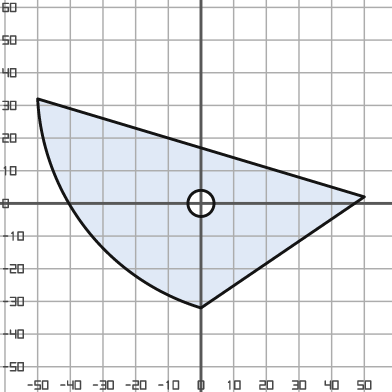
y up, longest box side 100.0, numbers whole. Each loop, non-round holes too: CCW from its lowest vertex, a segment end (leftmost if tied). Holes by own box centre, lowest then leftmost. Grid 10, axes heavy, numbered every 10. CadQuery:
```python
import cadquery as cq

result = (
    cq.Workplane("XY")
    .moveTo(0.0, -32.0)
    .lineTo(50.0, 2.0)
    .lineTo(-50.0, 32.0)
    .threePointArc((-35.0, -8.0), (0.0, -32.0))
    .close()
    .moveTo(0.0, 0.0)
    .circle(4.0)
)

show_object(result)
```